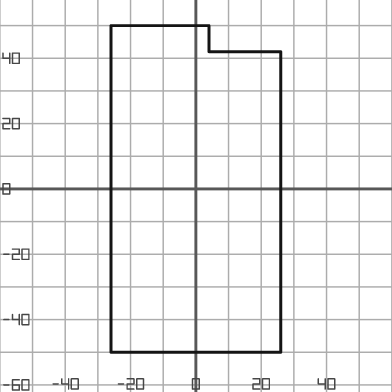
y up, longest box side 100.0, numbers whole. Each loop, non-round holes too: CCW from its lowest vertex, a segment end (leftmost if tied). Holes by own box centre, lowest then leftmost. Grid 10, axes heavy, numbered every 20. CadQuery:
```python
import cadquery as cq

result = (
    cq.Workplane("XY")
    .moveTo(-26.0, -50.0)
    .lineTo(26.0, -50.0)
    .lineTo(26.0, 42.0)
    .lineTo(4.0, 42.0)
    .lineTo(4.0, 50.0)
    .lineTo(-26.0, 50.0)
    .close()
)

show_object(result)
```